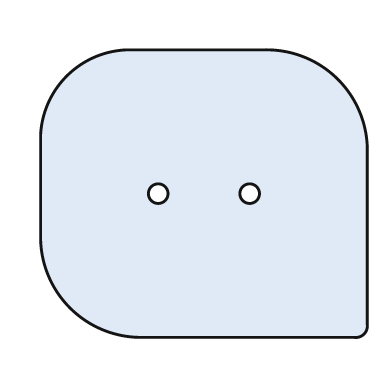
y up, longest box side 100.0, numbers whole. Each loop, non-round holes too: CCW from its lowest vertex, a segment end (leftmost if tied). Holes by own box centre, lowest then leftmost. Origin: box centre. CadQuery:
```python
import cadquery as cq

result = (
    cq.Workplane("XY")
    .moveTo(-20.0, -44.0)
    .lineTo(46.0, -44.0)
    .threePointArc((49.0, -43.0), (50.0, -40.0))
    .lineTo(50.0, 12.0)
    .threePointArc((41.0, 35.0), (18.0, 44.0))
    .lineTo(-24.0, 44.0)
    .threePointArc((-42.0, 36.0), (-50.0, 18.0))
    .lineTo(-50.0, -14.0)
    .threePointArc((-41.0, -35.0), (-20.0, -44.0))
    .close()
    .moveTo(-14.0, 0.0)
    .circle(3.0)
    .moveTo(14.0, 0.0)
    .circle(3.0)
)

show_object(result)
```